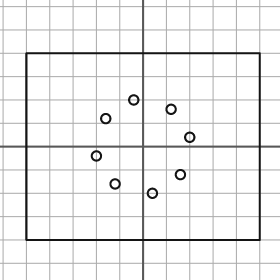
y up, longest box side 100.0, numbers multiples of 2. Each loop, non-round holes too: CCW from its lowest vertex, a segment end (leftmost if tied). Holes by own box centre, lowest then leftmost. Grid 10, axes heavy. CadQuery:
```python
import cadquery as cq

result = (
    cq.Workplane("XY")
    .moveTo(-50.0, -40.0)
    .lineTo(50.0, -40.0)
    .lineTo(50.0, 40.0)
    .lineTo(-50.0, 40.0)
    .close()
    .moveTo(4.0, -20.0)
    .circle(2.0)
    .moveTo(-12.0, -16.0)
    .circle(2.0)
    .moveTo(16.0, -12.0)
    .circle(2.0)
    .moveTo(-20.0, -4.0)
    .circle(2.0)
    .moveTo(20.0, 4.0)
    .circle(2.0)
    .moveTo(-16.0, 12.0)
    .circle(2.0)
    .moveTo(12.0, 16.0)
    .circle(2.0)
    .moveTo(-4.0, 20.0)
    .circle(2.0)
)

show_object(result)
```